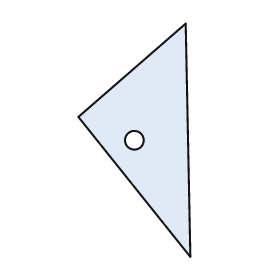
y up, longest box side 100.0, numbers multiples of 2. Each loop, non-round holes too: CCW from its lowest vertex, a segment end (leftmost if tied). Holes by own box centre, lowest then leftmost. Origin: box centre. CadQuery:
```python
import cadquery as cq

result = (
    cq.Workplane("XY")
    .moveTo(24.0, -50.0)
    .lineTo(22.0, 50.0)
    .lineTo(-24.0, 10.0)
    .close()
    .moveTo(0.0, 0.0)
    .circle(4.0)
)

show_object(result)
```